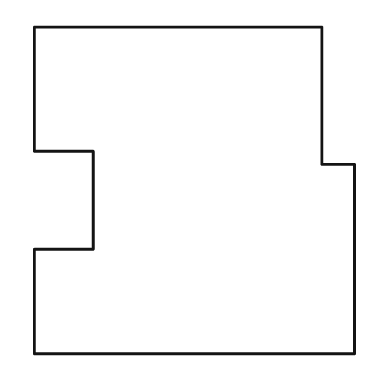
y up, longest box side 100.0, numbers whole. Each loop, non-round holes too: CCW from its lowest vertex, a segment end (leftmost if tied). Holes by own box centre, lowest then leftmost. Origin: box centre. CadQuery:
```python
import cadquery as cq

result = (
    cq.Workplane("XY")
    .moveTo(-49.0, -50.0)
    .lineTo(49.0, -50.0)
    .lineTo(49.0, 8.0)
    .lineTo(39.0, 8.0)
    .lineTo(39.0, 50.0)
    .lineTo(-49.0, 50.0)
    .lineTo(-49.0, 12.0)
    .lineTo(-31.0, 12.0)
    .lineTo(-31.0, -18.0)
    .lineTo(-49.0, -18.0)
    .close()
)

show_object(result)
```